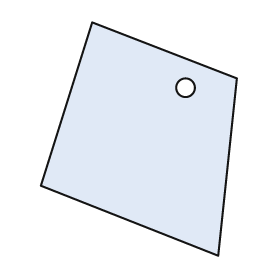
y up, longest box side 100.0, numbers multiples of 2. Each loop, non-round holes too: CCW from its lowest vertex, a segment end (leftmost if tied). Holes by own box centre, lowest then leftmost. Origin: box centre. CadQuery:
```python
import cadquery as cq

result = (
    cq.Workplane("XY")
    .moveTo(34.0, -50.0)
    .lineTo(42.0, 26.0)
    .lineTo(-20.0, 50.0)
    .lineTo(-42.0, -20.0)
    .close()
    .moveTo(20.0, 22.0)
    .circle(4.0)
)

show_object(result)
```